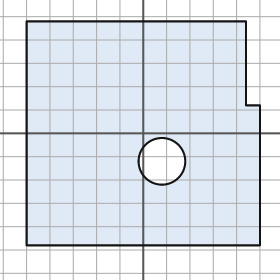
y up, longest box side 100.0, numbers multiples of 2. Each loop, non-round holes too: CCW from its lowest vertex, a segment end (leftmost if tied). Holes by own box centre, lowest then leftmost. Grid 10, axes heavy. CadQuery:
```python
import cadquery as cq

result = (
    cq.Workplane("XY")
    .moveTo(-50.0, -48.0)
    .lineTo(50.0, -48.0)
    .lineTo(50.0, 12.0)
    .lineTo(44.0, 12.0)
    .lineTo(44.0, 48.0)
    .lineTo(-50.0, 48.0)
    .close()
    .moveTo(8.0, -12.0)
    .circle(10.0)
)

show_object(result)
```